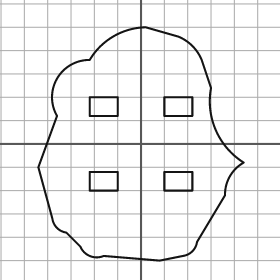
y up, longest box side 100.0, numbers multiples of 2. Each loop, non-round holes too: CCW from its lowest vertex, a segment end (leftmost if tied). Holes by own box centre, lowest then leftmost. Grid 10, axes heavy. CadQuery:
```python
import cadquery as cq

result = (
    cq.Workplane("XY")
    .moveTo(8.0, -50.0)
    .lineTo(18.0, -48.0)
    .threePointArc((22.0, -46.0), (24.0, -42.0))
    .lineTo(36.0, -22.0)
    .threePointArc((38.0, -14.0), (44.0, -8.0))
    .threePointArc((32.0, 6.0), (30.0, 24.0))
    .lineTo(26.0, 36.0)
    .threePointArc((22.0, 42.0), (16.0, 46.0))
    .lineTo(2.0, 50.0)
    .threePointArc((-12.0, 46.0), (-22.0, 36.0))
    .threePointArc((-36.0, 28.0), (-36.0, 12.0))
    .lineTo(-44.0, -10.0)
    .lineTo(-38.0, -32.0)
    .threePointArc((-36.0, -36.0), (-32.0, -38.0))
    .lineTo(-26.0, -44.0)
    .threePointArc((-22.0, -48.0), (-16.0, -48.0))
    .close()
    .moveTo(-22.0, -20.0)
    .lineTo(-10.0, -20.0)
    .lineTo(-10.0, -12.0)
    .lineTo(-22.0, -12.0)
    .close()
    .moveTo(10.0, -20.0)
    .lineTo(22.0, -20.0)
    .lineTo(22.0, -12.0)
    .lineTo(10.0, -12.0)
    .close()
    .moveTo(-22.0, 12.0)
    .lineTo(-10.0, 12.0)
    .lineTo(-10.0, 20.0)
    .lineTo(-22.0, 20.0)
    .close()
    .moveTo(10.0, 12.0)
    .lineTo(22.0, 12.0)
    .lineTo(22.0, 20.0)
    .lineTo(10.0, 20.0)
    .close()
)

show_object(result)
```